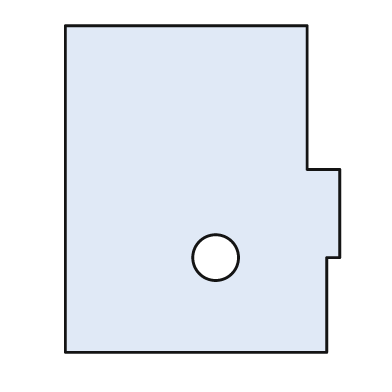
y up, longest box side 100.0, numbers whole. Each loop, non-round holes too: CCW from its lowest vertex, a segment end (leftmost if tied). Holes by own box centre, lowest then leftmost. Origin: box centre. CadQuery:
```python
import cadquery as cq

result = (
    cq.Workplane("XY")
    .moveTo(-42.0, -50.0)
    .lineTo(38.0, -50.0)
    .lineTo(38.0, -21.0)
    .lineTo(42.0, -21.0)
    .lineTo(42.0, 6.0)
    .lineTo(32.0, 6.0)
    .lineTo(32.0, 50.0)
    .lineTo(-42.0, 50.0)
    .close()
    .moveTo(4.0, -21.0)
    .circle(7.0)
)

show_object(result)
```